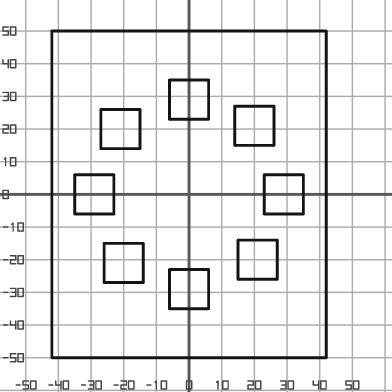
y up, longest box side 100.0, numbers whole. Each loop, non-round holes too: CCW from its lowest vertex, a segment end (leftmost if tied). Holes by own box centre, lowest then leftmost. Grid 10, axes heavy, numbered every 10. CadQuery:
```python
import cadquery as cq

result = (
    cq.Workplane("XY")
    .moveTo(-42.0, -50.0)
    .lineTo(42.0, -50.0)
    .lineTo(42.0, 50.0)
    .lineTo(-42.0, 50.0)
    .close()
    .moveTo(-6.0, -35.0)
    .lineTo(6.0, -35.0)
    .lineTo(6.0, -23.0)
    .lineTo(-6.0, -23.0)
    .close()
    .moveTo(-26.0, -27.0)
    .lineTo(-14.0, -27.0)
    .lineTo(-14.0, -15.0)
    .lineTo(-26.0, -15.0)
    .close()
    .moveTo(15.0, -26.0)
    .lineTo(27.0, -26.0)
    .lineTo(27.0, -14.0)
    .lineTo(15.0, -14.0)
    .close()
    .moveTo(-35.0, -6.0)
    .lineTo(-23.0, -6.0)
    .lineTo(-23.0, 6.0)
    .lineTo(-35.0, 6.0)
    .close()
    .moveTo(23.0, -6.0)
    .lineTo(35.0, -6.0)
    .lineTo(35.0, 6.0)
    .lineTo(23.0, 6.0)
    .close()
    .moveTo(-27.0, 14.0)
    .lineTo(-15.0, 14.0)
    .lineTo(-15.0, 26.0)
    .lineTo(-27.0, 26.0)
    .close()
    .moveTo(14.0, 15.0)
    .lineTo(26.0, 15.0)
    .lineTo(26.0, 27.0)
    .lineTo(14.0, 27.0)
    .close()
    .moveTo(-6.0, 23.0)
    .lineTo(6.0, 23.0)
    .lineTo(6.0, 35.0)
    .lineTo(-6.0, 35.0)
    .close()
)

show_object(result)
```